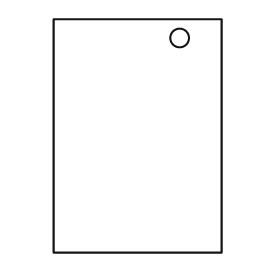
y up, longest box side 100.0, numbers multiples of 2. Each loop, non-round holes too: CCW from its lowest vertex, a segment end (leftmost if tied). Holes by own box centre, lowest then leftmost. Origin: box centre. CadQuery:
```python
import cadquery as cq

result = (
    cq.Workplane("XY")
    .moveTo(-36.0, -50.0)
    .lineTo(36.0, -50.0)
    .lineTo(36.0, 50.0)
    .lineTo(-36.0, 50.0)
    .close()
    .moveTo(18.0, 42.0)
    .circle(4.0)
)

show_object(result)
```